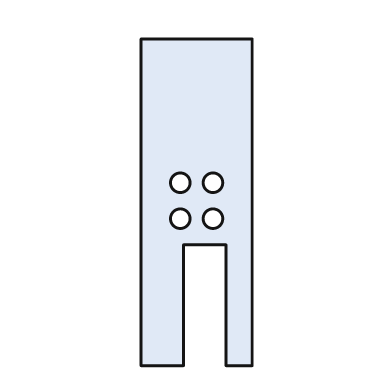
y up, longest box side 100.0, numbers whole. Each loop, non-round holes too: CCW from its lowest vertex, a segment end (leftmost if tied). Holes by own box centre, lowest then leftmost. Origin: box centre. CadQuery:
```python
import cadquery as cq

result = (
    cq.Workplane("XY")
    .moveTo(-17.0, -50.0)
    .lineTo(-4.0, -50.0)
    .lineTo(-4.0, -13.0)
    .lineTo(9.0, -13.0)
    .lineTo(9.0, -50.0)
    .lineTo(17.0, -50.0)
    .lineTo(17.0, 50.0)
    .lineTo(-17.0, 50.0)
    .close()
    .moveTo(-5.0, -5.0)
    .circle(3.0)
    .moveTo(5.0, -5.0)
    .circle(3.0)
    .moveTo(-5.0, 6.0)
    .circle(3.0)
    .moveTo(5.0, 6.0)
    .circle(3.0)
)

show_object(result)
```